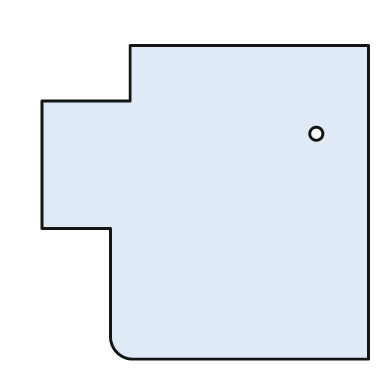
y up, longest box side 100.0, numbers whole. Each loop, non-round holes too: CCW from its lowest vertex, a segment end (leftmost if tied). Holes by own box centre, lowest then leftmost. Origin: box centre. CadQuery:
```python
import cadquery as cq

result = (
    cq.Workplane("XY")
    .moveTo(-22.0, -48.0)
    .lineTo(50.0, -48.0)
    .lineTo(50.0, 48.0)
    .lineTo(-23.0, 48.0)
    .lineTo(-23.0, 31.0)
    .lineTo(-50.0, 31.0)
    .lineTo(-50.0, -8.0)
    .lineTo(-29.0, -8.0)
    .lineTo(-29.0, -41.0)
    .threePointArc((-27.0, -46.0), (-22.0, -48.0))
    .close()
    .moveTo(34.0, 21.0)
    .circle(2.0)
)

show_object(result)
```